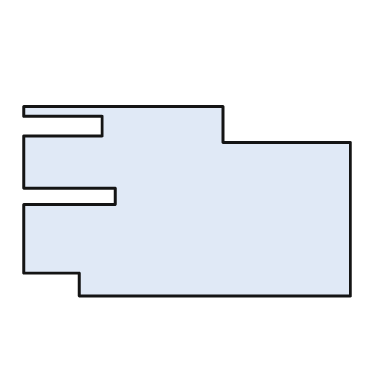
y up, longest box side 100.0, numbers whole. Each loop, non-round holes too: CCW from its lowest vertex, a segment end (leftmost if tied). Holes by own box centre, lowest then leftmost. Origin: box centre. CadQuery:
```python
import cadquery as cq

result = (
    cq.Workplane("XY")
    .moveTo(-33.0, -29.0)
    .lineTo(50.0, -29.0)
    .lineTo(50.0, 18.0)
    .lineTo(11.0, 18.0)
    .lineTo(11.0, 29.0)
    .lineTo(-50.0, 29.0)
    .lineTo(-50.0, 26.0)
    .lineTo(-26.0, 26.0)
    .lineTo(-26.0, 20.0)
    .lineTo(-50.0, 20.0)
    .lineTo(-50.0, 4.0)
    .lineTo(-22.0, 4.0)
    .lineTo(-22.0, -1.0)
    .lineTo(-50.0, -1.0)
    .lineTo(-50.0, -22.0)
    .lineTo(-33.0, -22.0)
    .close()
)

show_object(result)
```